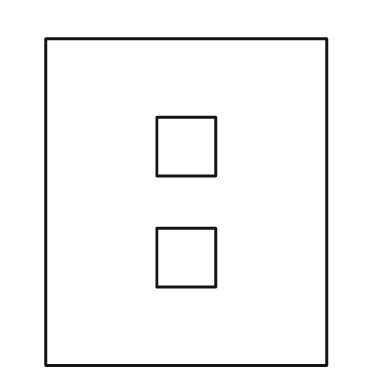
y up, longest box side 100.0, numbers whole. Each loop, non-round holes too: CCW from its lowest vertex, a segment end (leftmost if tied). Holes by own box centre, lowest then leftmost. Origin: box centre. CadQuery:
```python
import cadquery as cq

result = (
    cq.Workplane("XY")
    .moveTo(-43.0, -50.0)
    .lineTo(43.0, -50.0)
    .lineTo(43.0, 50.0)
    .lineTo(-43.0, 50.0)
    .close()
    .moveTo(-9.0, -26.0)
    .lineTo(9.0, -26.0)
    .lineTo(9.0, -8.0)
    .lineTo(-9.0, -8.0)
    .close()
    .moveTo(-9.0, 8.0)
    .lineTo(9.0, 8.0)
    .lineTo(9.0, 26.0)
    .lineTo(-9.0, 26.0)
    .close()
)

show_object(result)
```